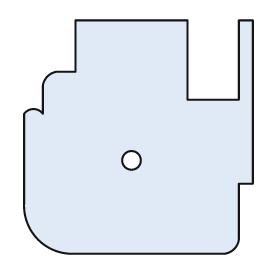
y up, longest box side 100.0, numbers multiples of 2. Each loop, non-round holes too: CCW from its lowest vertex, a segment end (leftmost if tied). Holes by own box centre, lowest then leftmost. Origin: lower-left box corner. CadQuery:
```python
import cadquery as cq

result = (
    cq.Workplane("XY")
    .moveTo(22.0, 0.0)
    .lineTo(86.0, 0.0)
    .threePointArc((90.0, 2.0), (92.0, 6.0))
    .lineTo(92.0, 30.0)
    .lineTo(98.0, 30.0)
    .lineTo(98.0, 100.0)
    .lineTo(92.0, 100.0)
    .lineTo(92.0, 66.0)
    .lineTo(70.0, 66.0)
    .lineTo(70.0, 100.0)
    .lineTo(22.0, 100.0)
    .lineTo(22.0, 78.0)
    .lineTo(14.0, 78.0)
    .threePointArc((10.0, 76.0), (8.0, 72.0))
    .lineTo(8.0, 60.0)
    .threePointArc((4.0, 62.0), (0.0, 60.0))
    .lineTo(0.0, 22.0)
    .threePointArc((6.0, 6.0), (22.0, 0.0))
    .close()
    .moveTo(46.0, 40.0)
    .circle(4.0)
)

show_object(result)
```